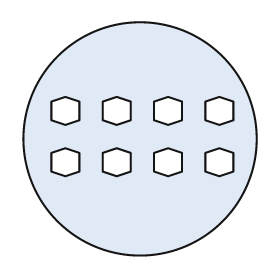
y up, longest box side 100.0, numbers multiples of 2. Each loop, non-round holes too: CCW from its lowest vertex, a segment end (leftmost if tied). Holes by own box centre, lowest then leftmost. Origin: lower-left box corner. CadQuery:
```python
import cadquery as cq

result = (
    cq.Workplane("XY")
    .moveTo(50.0, 50.0)
    .circle(50.0)
    .moveTo(18.0, 34.0)
    .lineTo(24.0, 36.0)
    .lineTo(24.0, 44.0)
    .lineTo(18.0, 46.0)
    .lineTo(12.0, 44.0)
    .lineTo(12.0, 36.0)
    .close()
    .moveTo(40.0, 34.0)
    .lineTo(46.0, 36.0)
    .lineTo(46.0, 44.0)
    .lineTo(40.0, 46.0)
    .lineTo(34.0, 44.0)
    .lineTo(34.0, 36.0)
    .close()
    .moveTo(62.0, 34.0)
    .lineTo(68.0, 36.0)
    .lineTo(68.0, 44.0)
    .lineTo(62.0, 46.0)
    .lineTo(56.0, 44.0)
    .lineTo(56.0, 36.0)
    .close()
    .moveTo(84.0, 34.0)
    .lineTo(90.0, 36.0)
    .lineTo(90.0, 44.0)
    .lineTo(84.0, 46.0)
    .lineTo(78.0, 44.0)
    .lineTo(78.0, 36.0)
    .close()
    .moveTo(18.0, 56.0)
    .lineTo(24.0, 58.0)
    .lineTo(24.0, 66.0)
    .lineTo(18.0, 68.0)
    .lineTo(12.0, 66.0)
    .lineTo(12.0, 58.0)
    .close()
    .moveTo(40.0, 56.0)
    .lineTo(46.0, 58.0)
    .lineTo(46.0, 66.0)
    .lineTo(40.0, 68.0)
    .lineTo(34.0, 66.0)
    .lineTo(34.0, 58.0)
    .close()
    .moveTo(62.0, 56.0)
    .lineTo(68.0, 58.0)
    .lineTo(68.0, 66.0)
    .lineTo(62.0, 68.0)
    .lineTo(56.0, 66.0)
    .lineTo(56.0, 58.0)
    .close()
    .moveTo(84.0, 56.0)
    .lineTo(90.0, 58.0)
    .lineTo(90.0, 66.0)
    .lineTo(84.0, 68.0)
    .lineTo(78.0, 66.0)
    .lineTo(78.0, 58.0)
    .close()
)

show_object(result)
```